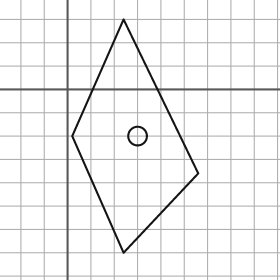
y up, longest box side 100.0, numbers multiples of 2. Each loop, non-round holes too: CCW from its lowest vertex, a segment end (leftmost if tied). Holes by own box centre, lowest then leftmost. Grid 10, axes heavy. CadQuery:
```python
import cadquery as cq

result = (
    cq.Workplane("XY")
    .moveTo(24.0, -70.0)
    .lineTo(56.0, -36.0)
    .lineTo(24.0, 30.0)
    .lineTo(2.0, -20.0)
    .close()
    .moveTo(30.0, -20.0)
    .circle(4.0)
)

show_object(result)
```